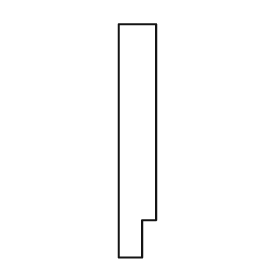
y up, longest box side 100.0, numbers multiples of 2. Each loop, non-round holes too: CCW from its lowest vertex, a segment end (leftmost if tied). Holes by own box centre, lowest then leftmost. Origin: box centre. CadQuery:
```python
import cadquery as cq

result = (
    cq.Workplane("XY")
    .moveTo(-8.0, -50.0)
    .lineTo(2.0, -50.0)
    .lineTo(2.0, -34.0)
    .lineTo(8.0, -34.0)
    .lineTo(8.0, 50.0)
    .lineTo(-8.0, 50.0)
    .close()
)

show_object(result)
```